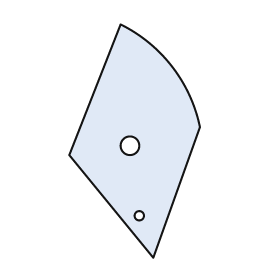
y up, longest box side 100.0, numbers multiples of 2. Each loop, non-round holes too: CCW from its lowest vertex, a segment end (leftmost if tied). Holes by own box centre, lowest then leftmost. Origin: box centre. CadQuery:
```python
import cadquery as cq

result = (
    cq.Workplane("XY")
    .moveTo(8.0, -50.0)
    .lineTo(28.0, 6.0)
    .threePointArc((16.0, 32.0), (-6.0, 50.0))
    .lineTo(-28.0, -6.0)
    .close()
    .moveTo(2.0, -32.0)
    .circle(2.0)
    .moveTo(-2.0, -2.0)
    .circle(4.0)
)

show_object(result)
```